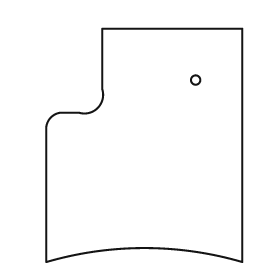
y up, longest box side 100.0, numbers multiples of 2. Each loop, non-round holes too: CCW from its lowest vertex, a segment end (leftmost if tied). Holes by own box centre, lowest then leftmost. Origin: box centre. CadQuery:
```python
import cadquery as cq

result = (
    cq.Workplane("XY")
    .moveTo(-42.0, -50.0)
    .threePointArc((0.0, -44.0), (42.0, -50.0))
    .lineTo(42.0, 50.0)
    .lineTo(-18.0, 50.0)
    .lineTo(-18.0, 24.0)
    .threePointArc((-20.0, 16.0), (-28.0, 14.0))
    .lineTo(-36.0, 14.0)
    .threePointArc((-40.0, 12.0), (-42.0, 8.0))
    .close()
    .moveTo(22.0, 28.0)
    .circle(2.0)
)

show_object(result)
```